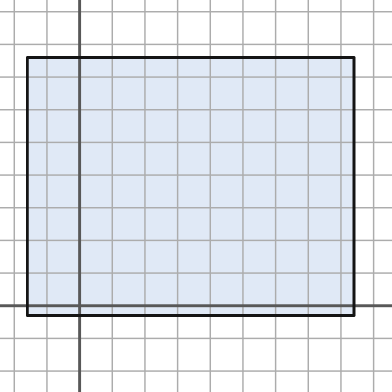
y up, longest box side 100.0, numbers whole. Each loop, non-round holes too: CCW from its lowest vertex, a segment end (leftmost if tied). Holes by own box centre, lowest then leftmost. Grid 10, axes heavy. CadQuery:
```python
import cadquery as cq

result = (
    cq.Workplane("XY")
    .moveTo(-16.0, -3.0)
    .lineTo(84.0, -3.0)
    .lineTo(84.0, 76.0)
    .lineTo(-16.0, 76.0)
    .close()
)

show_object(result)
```